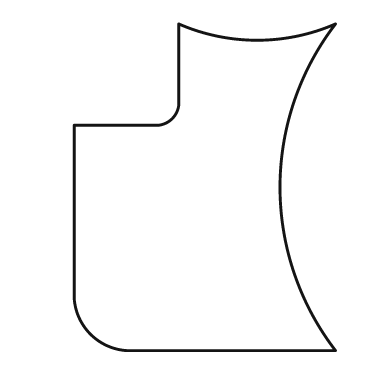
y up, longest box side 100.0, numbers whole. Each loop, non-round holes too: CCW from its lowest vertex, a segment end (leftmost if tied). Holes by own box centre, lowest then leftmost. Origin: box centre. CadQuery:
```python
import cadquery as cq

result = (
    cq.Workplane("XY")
    .moveTo(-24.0, -50.0)
    .lineTo(40.0, -50.0)
    .threePointArc((23.0, 0.0), (40.0, 50.0))
    .threePointArc((16.0, 45.0), (-8.0, 50.0))
    .lineTo(-8.0, 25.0)
    .threePointArc((-10.0, 21.0), (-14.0, 19.0))
    .lineTo(-40.0, 19.0)
    .lineTo(-40.0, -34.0)
    .threePointArc((-35.0, -45.0), (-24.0, -50.0))
    .close()
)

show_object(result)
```